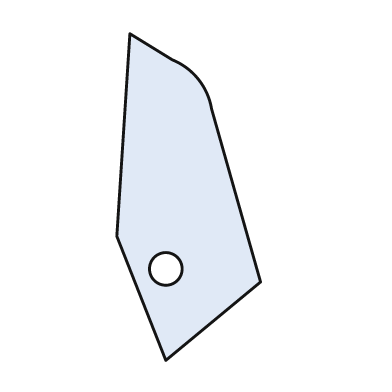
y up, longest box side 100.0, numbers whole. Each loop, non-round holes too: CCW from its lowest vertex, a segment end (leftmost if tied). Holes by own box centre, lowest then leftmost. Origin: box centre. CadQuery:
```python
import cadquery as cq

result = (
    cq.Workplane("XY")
    .moveTo(-7.0, -50.0)
    .lineTo(22.0, -26.0)
    .lineTo(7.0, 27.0)
    .threePointArc((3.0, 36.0), (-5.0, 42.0))
    .lineTo(-18.0, 50.0)
    .lineTo(-22.0, -12.0)
    .close()
    .moveTo(-7.0, -22.0)
    .circle(5.0)
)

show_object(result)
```